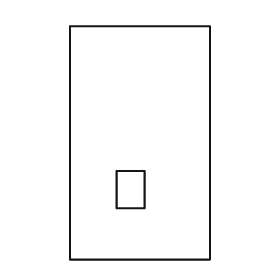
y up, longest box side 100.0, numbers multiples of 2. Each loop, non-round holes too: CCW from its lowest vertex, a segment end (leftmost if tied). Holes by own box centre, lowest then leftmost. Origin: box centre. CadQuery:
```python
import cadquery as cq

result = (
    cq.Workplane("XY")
    .moveTo(-30.0, -50.0)
    .lineTo(30.0, -50.0)
    .lineTo(30.0, 50.0)
    .lineTo(-30.0, 50.0)
    .close()
    .moveTo(-10.0, -28.0)
    .lineTo(2.0, -28.0)
    .lineTo(2.0, -12.0)
    .lineTo(-10.0, -12.0)
    .close()
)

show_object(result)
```